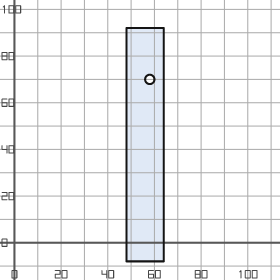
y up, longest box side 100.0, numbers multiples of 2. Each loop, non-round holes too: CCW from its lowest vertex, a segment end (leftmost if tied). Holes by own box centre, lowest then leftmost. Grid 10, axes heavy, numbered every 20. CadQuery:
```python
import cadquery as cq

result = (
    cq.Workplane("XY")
    .moveTo(48.0, -8.0)
    .lineTo(64.0, -8.0)
    .lineTo(64.0, 92.0)
    .lineTo(48.0, 92.0)
    .close()
    .moveTo(58.0, 70.0)
    .circle(2.0)
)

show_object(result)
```